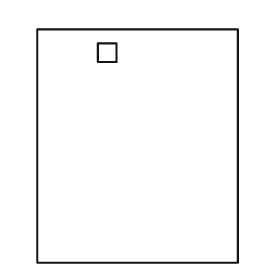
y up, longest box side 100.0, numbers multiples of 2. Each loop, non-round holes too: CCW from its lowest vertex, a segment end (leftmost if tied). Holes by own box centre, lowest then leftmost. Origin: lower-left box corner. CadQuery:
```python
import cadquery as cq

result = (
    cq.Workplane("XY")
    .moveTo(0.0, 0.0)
    .lineTo(86.0, 0.0)
    .lineTo(86.0, 100.0)
    .lineTo(0.0, 100.0)
    .close()
    .moveTo(26.0, 86.0)
    .lineTo(34.0, 86.0)
    .lineTo(34.0, 94.0)
    .lineTo(26.0, 94.0)
    .close()
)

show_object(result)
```